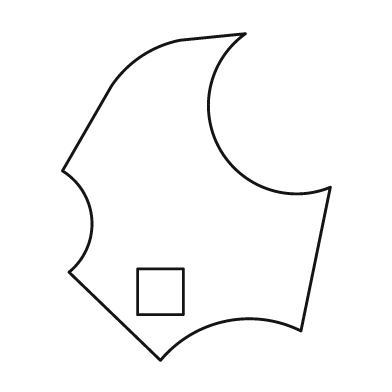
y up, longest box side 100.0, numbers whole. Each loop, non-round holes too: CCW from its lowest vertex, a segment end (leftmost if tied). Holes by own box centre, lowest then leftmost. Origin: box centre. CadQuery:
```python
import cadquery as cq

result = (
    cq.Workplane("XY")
    .moveTo(-11.0, -50.0)
    .threePointArc((9.0, -38.0), (32.0, -41.0))
    .lineTo(41.0, 3.0)
    .threePointArc((7.0, 15.0), (15.0, 50.0))
    .lineTo(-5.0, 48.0)
    .threePointArc((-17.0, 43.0), (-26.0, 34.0))
    .lineTo(-41.0, 8.0)
    .threePointArc((-32.0, -7.0), (-39.0, -23.0))
    .close()
    .moveTo(-18.0, -36.0)
    .lineTo(-4.0, -36.0)
    .lineTo(-4.0, -22.0)
    .lineTo(-18.0, -22.0)
    .close()
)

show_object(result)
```